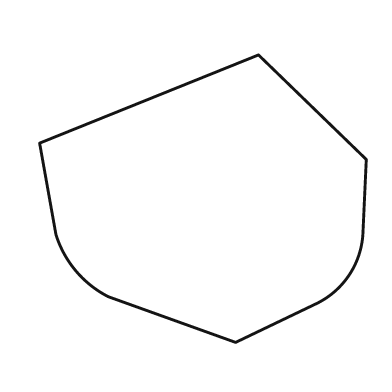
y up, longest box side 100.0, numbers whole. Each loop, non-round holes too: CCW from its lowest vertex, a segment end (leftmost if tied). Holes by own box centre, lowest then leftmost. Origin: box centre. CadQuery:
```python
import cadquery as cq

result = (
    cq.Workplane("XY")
    .moveTo(10.0, -44.0)
    .lineTo(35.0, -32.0)
    .threePointArc((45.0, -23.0), (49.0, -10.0))
    .lineTo(50.0, 12.0)
    .lineTo(17.0, 44.0)
    .lineTo(-50.0, 17.0)
    .lineTo(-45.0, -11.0)
    .threePointArc((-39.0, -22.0), (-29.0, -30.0))
    .close()
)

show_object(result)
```